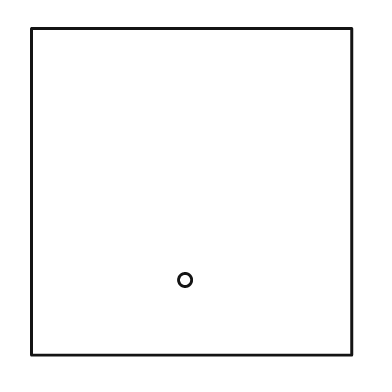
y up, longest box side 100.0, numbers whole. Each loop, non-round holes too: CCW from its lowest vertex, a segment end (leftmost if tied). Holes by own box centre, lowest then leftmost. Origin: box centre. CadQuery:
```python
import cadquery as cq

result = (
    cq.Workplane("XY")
    .moveTo(-49.0, -50.0)
    .lineTo(49.0, -50.0)
    .lineTo(49.0, 50.0)
    .lineTo(-49.0, 50.0)
    .close()
    .moveTo(-2.0, -27.0)
    .circle(2.0)
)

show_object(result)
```